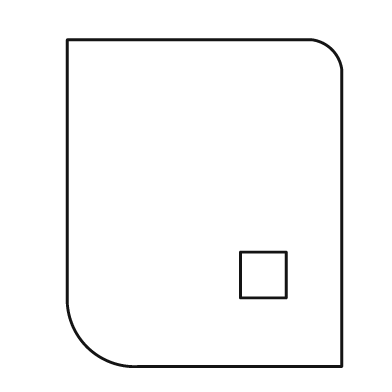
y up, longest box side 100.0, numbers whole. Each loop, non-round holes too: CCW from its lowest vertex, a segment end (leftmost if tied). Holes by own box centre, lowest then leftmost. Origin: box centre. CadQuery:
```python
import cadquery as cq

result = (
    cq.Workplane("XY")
    .moveTo(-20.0, -50.0)
    .lineTo(42.0, -50.0)
    .lineTo(42.0, 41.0)
    .threePointArc((39.0, 47.0), (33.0, 50.0))
    .lineTo(-42.0, 50.0)
    .lineTo(-42.0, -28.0)
    .threePointArc((-36.0, -44.0), (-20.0, -50.0))
    .close()
    .moveTo(11.0, -29.0)
    .lineTo(25.0, -29.0)
    .lineTo(25.0, -15.0)
    .lineTo(11.0, -15.0)
    .close()
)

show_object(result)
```